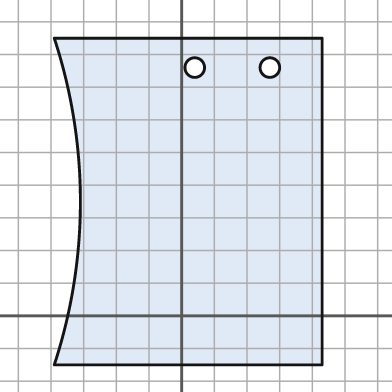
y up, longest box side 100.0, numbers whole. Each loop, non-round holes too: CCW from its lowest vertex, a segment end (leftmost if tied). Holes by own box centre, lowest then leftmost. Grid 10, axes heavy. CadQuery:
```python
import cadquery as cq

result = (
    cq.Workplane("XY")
    .moveTo(-39.0, -15.0)
    .lineTo(43.0, -15.0)
    .lineTo(43.0, 85.0)
    .lineTo(-39.0, 85.0)
    .threePointArc((-31.0, 35.0), (-39.0, -15.0))
    .close()
    .moveTo(4.0, 76.0)
    .circle(3.0)
    .moveTo(27.0, 76.0)
    .circle(3.0)
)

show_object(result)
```